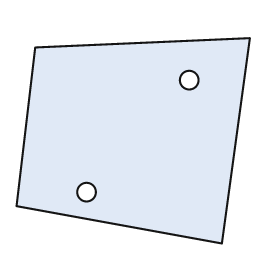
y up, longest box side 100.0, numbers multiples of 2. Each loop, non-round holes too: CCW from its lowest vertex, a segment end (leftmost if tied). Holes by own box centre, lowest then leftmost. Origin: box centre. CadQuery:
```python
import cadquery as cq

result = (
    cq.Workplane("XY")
    .moveTo(38.0, -44.0)
    .lineTo(50.0, 44.0)
    .lineTo(-42.0, 40.0)
    .lineTo(-50.0, -28.0)
    .close()
    .moveTo(-20.0, -22.0)
    .circle(4.0)
    .moveTo(24.0, 26.0)
    .circle(4.0)
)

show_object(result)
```